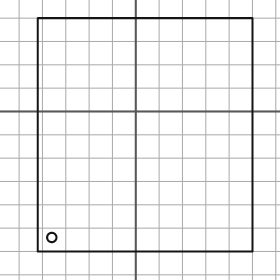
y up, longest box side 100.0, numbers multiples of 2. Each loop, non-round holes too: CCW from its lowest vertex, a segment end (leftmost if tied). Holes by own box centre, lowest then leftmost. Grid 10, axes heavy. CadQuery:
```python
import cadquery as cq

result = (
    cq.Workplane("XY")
    .moveTo(-42.0, -60.0)
    .lineTo(50.0, -60.0)
    .lineTo(50.0, 40.0)
    .lineTo(-42.0, 40.0)
    .close()
    .moveTo(-36.0, -54.0)
    .circle(2.0)
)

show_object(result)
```